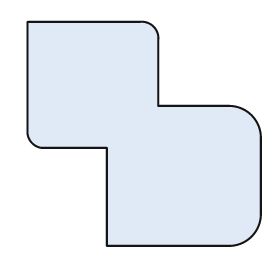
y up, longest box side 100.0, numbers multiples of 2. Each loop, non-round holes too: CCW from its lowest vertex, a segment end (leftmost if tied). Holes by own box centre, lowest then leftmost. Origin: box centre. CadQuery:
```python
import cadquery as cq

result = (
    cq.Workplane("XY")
    .moveTo(-16.0, -48.0)
    .lineTo(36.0, -48.0)
    .threePointArc((46.0, -44.0), (50.0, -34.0))
    .lineTo(50.0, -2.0)
    .threePointArc((46.0, 8.0), (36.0, 12.0))
    .lineTo(6.0, 12.0)
    .lineTo(6.0, 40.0)
    .threePointArc((4.0, 46.0), (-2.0, 48.0))
    .lineTo(-50.0, 48.0)
    .lineTo(-50.0, 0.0)
    .threePointArc((-48.0, -4.0), (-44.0, -6.0))
    .lineTo(-16.0, -6.0)
    .close()
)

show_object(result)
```